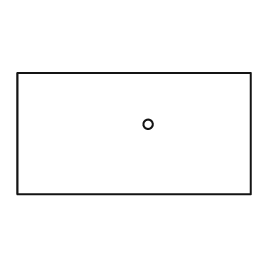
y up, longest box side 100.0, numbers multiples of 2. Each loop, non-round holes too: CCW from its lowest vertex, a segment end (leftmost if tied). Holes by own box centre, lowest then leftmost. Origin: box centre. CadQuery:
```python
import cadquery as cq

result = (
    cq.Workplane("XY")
    .moveTo(-50.0, -26.0)
    .lineTo(50.0, -26.0)
    .lineTo(50.0, 26.0)
    .lineTo(-50.0, 26.0)
    .close()
    .moveTo(6.0, 4.0)
    .circle(2.0)
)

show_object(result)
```